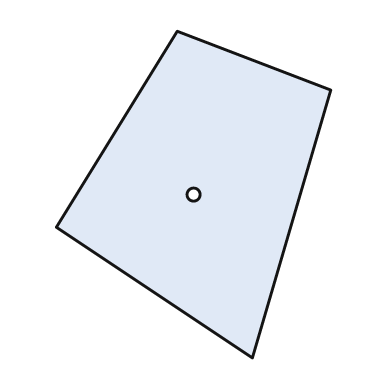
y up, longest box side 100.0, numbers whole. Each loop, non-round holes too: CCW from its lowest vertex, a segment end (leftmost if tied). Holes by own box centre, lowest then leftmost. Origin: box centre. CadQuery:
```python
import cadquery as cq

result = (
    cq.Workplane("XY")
    .moveTo(18.0, -50.0)
    .lineTo(42.0, 32.0)
    .lineTo(-5.0, 50.0)
    .lineTo(-42.0, -10.0)
    .close()
    .moveTo(0.0, 0.0)
    .circle(2.0)
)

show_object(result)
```